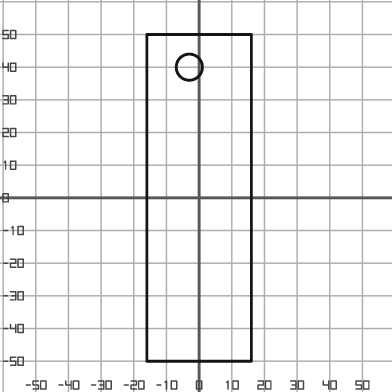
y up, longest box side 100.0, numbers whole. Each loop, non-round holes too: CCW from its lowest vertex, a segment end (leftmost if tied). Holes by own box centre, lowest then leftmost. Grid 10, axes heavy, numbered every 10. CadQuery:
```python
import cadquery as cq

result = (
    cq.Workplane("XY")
    .moveTo(-16.0, -50.0)
    .lineTo(16.0, -50.0)
    .lineTo(16.0, 50.0)
    .lineTo(-16.0, 50.0)
    .close()
    .moveTo(-3.0, 40.0)
    .circle(4.0)
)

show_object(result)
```